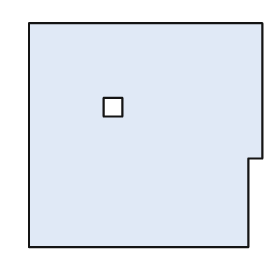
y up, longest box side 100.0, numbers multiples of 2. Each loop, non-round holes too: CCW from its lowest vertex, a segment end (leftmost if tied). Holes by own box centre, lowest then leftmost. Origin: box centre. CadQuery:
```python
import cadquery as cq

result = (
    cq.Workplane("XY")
    .moveTo(-50.0, -48.0)
    .lineTo(44.0, -48.0)
    .lineTo(44.0, -10.0)
    .lineTo(50.0, -10.0)
    .lineTo(50.0, 48.0)
    .lineTo(-50.0, 48.0)
    .close()
    .moveTo(-18.0, 8.0)
    .lineTo(-10.0, 8.0)
    .lineTo(-10.0, 16.0)
    .lineTo(-18.0, 16.0)
    .close()
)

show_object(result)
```